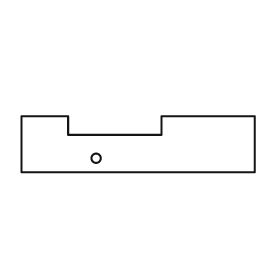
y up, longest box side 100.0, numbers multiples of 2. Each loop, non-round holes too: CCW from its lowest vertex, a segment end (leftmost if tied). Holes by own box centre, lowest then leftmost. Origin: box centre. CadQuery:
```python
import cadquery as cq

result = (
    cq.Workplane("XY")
    .moveTo(-50.0, -12.0)
    .lineTo(50.0, -12.0)
    .lineTo(50.0, 12.0)
    .lineTo(10.0, 12.0)
    .lineTo(10.0, 4.0)
    .lineTo(-30.0, 4.0)
    .lineTo(-30.0, 12.0)
    .lineTo(-50.0, 12.0)
    .close()
    .moveTo(-18.0, -6.0)
    .circle(2.0)
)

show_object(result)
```